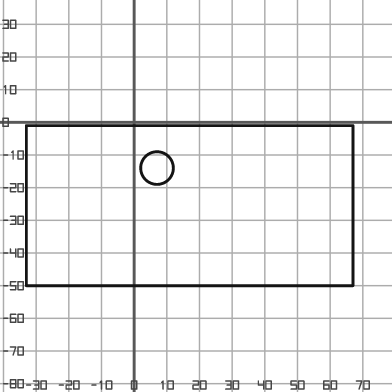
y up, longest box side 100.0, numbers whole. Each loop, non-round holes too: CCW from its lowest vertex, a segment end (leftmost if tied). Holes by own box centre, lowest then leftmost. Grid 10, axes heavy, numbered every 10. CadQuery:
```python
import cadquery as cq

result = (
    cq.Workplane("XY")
    .moveTo(-33.0, -50.0)
    .lineTo(67.0, -50.0)
    .lineTo(67.0, -1.0)
    .lineTo(-33.0, -1.0)
    .close()
    .moveTo(7.0, -14.0)
    .circle(5.0)
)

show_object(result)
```